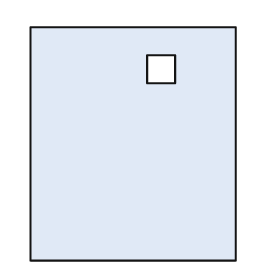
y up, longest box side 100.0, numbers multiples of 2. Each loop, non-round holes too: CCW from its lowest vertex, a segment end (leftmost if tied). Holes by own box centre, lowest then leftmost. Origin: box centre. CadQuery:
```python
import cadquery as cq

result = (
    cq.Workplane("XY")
    .moveTo(-44.0, -50.0)
    .lineTo(44.0, -50.0)
    .lineTo(44.0, 50.0)
    .lineTo(-44.0, 50.0)
    .close()
    .moveTo(6.0, 26.0)
    .lineTo(18.0, 26.0)
    .lineTo(18.0, 38.0)
    .lineTo(6.0, 38.0)
    .close()
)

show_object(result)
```